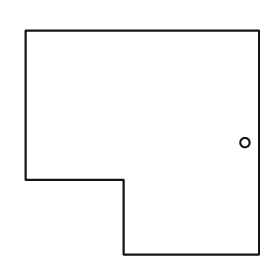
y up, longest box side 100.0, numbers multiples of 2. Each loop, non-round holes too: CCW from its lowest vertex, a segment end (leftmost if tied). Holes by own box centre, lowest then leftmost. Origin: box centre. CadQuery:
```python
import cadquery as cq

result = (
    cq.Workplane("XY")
    .moveTo(-8.0, -48.0)
    .lineTo(50.0, -48.0)
    .lineTo(50.0, 48.0)
    .lineTo(-50.0, 48.0)
    .lineTo(-50.0, -16.0)
    .lineTo(-8.0, -16.0)
    .close()
    .moveTo(44.0, 0.0)
    .circle(2.0)
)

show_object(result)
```